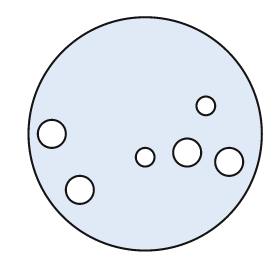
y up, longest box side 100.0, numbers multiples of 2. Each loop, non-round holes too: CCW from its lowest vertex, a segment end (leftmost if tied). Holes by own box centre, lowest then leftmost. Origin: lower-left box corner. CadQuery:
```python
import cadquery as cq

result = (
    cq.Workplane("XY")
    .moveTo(50.0, 50.0)
    .circle(50.0)
    .moveTo(22.0, 26.0)
    .circle(6.0)
    .moveTo(86.0, 38.0)
    .circle(6.0)
    .moveTo(50.0, 40.0)
    .circle(4.0)
    .moveTo(68.0, 42.0)
    .circle(6.0)
    .moveTo(10.0, 50.0)
    .circle(6.0)
    .moveTo(76.0, 62.0)
    .circle(4.0)
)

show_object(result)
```